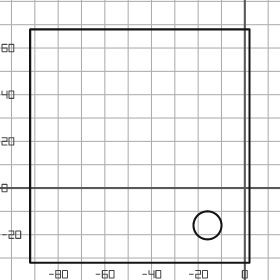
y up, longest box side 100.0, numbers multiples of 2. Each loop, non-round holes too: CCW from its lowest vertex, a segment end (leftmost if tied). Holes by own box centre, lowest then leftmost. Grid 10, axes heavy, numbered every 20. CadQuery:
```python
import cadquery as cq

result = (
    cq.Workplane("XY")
    .moveTo(-92.0, -32.0)
    .lineTo(2.0, -32.0)
    .lineTo(2.0, 68.0)
    .lineTo(-92.0, 68.0)
    .close()
    .moveTo(-16.0, -16.0)
    .circle(6.0)
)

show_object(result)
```